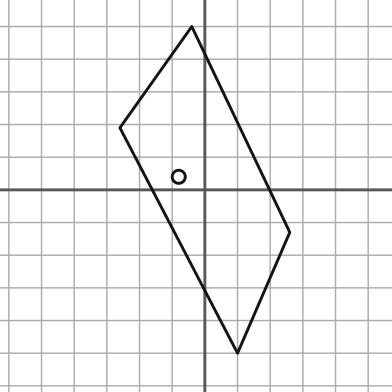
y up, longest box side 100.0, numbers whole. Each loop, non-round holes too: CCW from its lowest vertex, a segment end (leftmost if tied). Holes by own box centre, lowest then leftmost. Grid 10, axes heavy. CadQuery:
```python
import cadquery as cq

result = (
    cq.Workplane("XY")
    .moveTo(10.0, -50.0)
    .lineTo(26.0, -13.0)
    .lineTo(-4.0, 50.0)
    .lineTo(-26.0, 19.0)
    .close()
    .moveTo(-8.0, 4.0)
    .circle(2.0)
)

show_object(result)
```